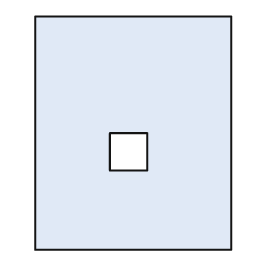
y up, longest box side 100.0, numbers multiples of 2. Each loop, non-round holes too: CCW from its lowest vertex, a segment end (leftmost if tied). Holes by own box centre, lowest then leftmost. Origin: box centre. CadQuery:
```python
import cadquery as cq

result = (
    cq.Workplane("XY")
    .moveTo(-42.0, -50.0)
    .lineTo(42.0, -50.0)
    .lineTo(42.0, 50.0)
    .lineTo(-42.0, 50.0)
    .close()
    .moveTo(-10.0, -16.0)
    .lineTo(6.0, -16.0)
    .lineTo(6.0, 0.0)
    .lineTo(-10.0, 0.0)
    .close()
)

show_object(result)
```